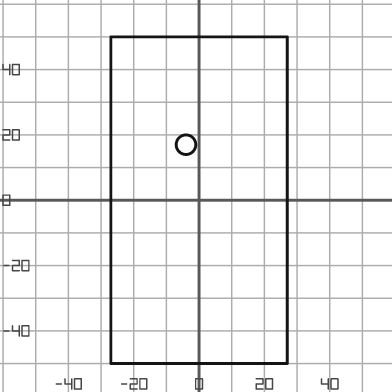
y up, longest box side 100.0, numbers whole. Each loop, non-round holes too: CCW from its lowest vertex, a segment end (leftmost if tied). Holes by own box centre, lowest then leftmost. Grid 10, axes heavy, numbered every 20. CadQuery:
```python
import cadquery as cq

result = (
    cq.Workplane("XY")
    .moveTo(-27.0, -50.0)
    .lineTo(27.0, -50.0)
    .lineTo(27.0, 50.0)
    .lineTo(-27.0, 50.0)
    .close()
    .moveTo(-4.0, 17.0)
    .circle(3.0)
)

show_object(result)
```